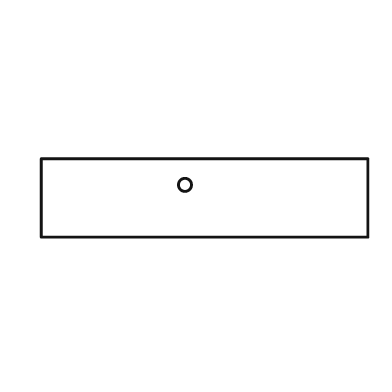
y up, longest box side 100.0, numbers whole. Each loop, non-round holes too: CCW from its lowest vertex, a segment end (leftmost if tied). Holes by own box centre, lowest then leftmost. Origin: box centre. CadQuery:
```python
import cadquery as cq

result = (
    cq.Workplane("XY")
    .moveTo(-50.0, -12.0)
    .lineTo(50.0, -12.0)
    .lineTo(50.0, 12.0)
    .lineTo(-50.0, 12.0)
    .close()
    .moveTo(-6.0, 4.0)
    .circle(2.0)
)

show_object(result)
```